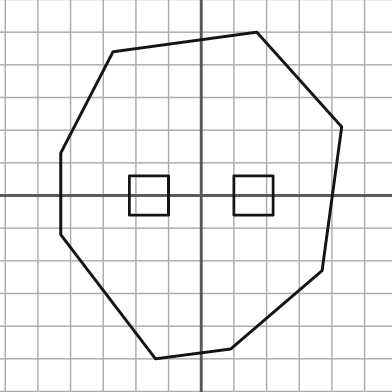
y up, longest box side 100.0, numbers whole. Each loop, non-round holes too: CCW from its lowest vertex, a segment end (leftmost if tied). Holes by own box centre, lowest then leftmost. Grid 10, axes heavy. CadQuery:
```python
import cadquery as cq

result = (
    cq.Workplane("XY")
    .moveTo(-14.0, -50.0)
    .lineTo(9.0, -47.0)
    .lineTo(37.0, -23.0)
    .lineTo(43.0, 21.0)
    .lineTo(17.0, 50.0)
    .lineTo(-27.0, 44.0)
    .lineTo(-43.0, 13.0)
    .lineTo(-43.0, -12.0)
    .close()
    .moveTo(-22.0, -6.0)
    .lineTo(-10.0, -6.0)
    .lineTo(-10.0, 6.0)
    .lineTo(-22.0, 6.0)
    .close()
    .moveTo(10.0, -6.0)
    .lineTo(22.0, -6.0)
    .lineTo(22.0, 6.0)
    .lineTo(10.0, 6.0)
    .close()
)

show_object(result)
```